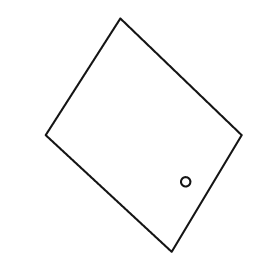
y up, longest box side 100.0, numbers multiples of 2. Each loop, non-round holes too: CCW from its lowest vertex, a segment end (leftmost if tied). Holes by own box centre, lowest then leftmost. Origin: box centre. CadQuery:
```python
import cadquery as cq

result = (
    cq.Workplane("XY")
    .moveTo(12.0, -50.0)
    .lineTo(42.0, 0.0)
    .lineTo(-10.0, 50.0)
    .lineTo(-42.0, 0.0)
    .close()
    .moveTo(18.0, -20.0)
    .circle(2.0)
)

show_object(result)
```